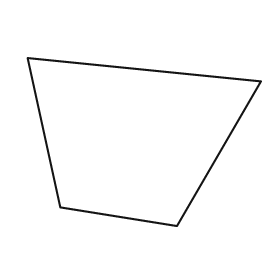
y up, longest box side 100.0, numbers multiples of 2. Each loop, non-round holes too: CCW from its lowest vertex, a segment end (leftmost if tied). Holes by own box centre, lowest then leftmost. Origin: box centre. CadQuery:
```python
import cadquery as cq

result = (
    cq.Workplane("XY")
    .moveTo(14.0, -36.0)
    .lineTo(50.0, 26.0)
    .lineTo(-50.0, 36.0)
    .lineTo(-36.0, -28.0)
    .close()
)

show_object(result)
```